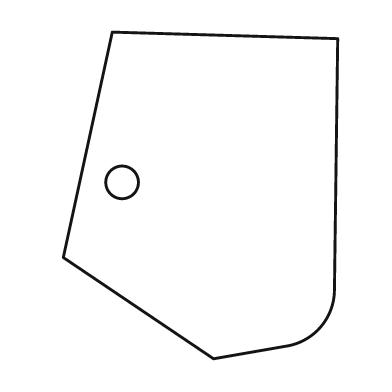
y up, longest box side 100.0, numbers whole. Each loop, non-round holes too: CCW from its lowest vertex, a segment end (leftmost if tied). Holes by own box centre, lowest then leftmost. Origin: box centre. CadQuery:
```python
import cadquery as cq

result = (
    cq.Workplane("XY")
    .moveTo(4.0, -50.0)
    .lineTo(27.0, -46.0)
    .threePointArc((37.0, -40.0), (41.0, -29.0))
    .lineTo(42.0, 48.0)
    .lineTo(-27.0, 50.0)
    .lineTo(-42.0, -19.0)
    .close()
    .moveTo(-24.0, 4.0)
    .circle(5.0)
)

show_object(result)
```